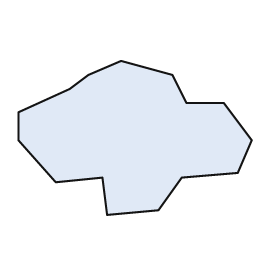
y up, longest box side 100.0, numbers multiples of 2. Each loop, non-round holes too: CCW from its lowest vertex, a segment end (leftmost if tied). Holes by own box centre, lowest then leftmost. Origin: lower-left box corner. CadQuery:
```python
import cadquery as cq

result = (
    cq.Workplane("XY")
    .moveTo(38.0, 0.0)
    .lineTo(60.0, 2.0)
    .lineTo(70.0, 16.0)
    .lineTo(94.0, 18.0)
    .lineTo(100.0, 32.0)
    .lineTo(88.0, 48.0)
    .lineTo(72.0, 48.0)
    .lineTo(66.0, 60.0)
    .lineTo(44.0, 66.0)
    .lineTo(30.0, 60.0)
    .lineTo(22.0, 54.0)
    .lineTo(0.0, 44.0)
    .lineTo(0.0, 32.0)
    .lineTo(16.0, 14.0)
    .lineTo(36.0, 16.0)
    .close()
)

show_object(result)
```